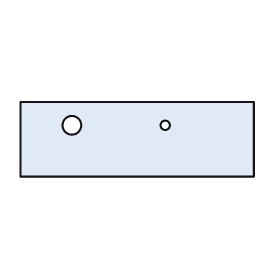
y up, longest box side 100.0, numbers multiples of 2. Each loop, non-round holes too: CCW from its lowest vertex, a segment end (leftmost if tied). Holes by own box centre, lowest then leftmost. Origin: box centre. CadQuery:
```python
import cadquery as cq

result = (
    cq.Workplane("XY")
    .moveTo(-50.0, -16.0)
    .lineTo(50.0, -16.0)
    .lineTo(50.0, 16.0)
    .lineTo(-50.0, 16.0)
    .close()
    .moveTo(-28.0, 6.0)
    .circle(4.0)
    .moveTo(12.0, 6.0)
    .circle(2.0)
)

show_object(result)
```